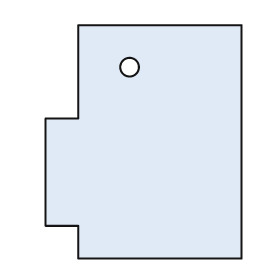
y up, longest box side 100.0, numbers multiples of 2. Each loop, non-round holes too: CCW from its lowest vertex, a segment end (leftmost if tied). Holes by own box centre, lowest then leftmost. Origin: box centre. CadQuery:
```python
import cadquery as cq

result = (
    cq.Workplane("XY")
    .moveTo(-28.0, -50.0)
    .lineTo(42.0, -50.0)
    .lineTo(42.0, 50.0)
    .lineTo(-28.0, 50.0)
    .lineTo(-28.0, 10.0)
    .lineTo(-42.0, 10.0)
    .lineTo(-42.0, -36.0)
    .lineTo(-28.0, -36.0)
    .close()
    .moveTo(-6.0, 32.0)
    .circle(4.0)
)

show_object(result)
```